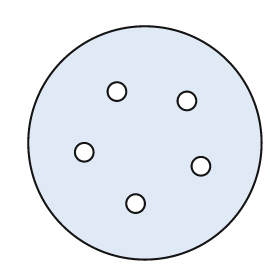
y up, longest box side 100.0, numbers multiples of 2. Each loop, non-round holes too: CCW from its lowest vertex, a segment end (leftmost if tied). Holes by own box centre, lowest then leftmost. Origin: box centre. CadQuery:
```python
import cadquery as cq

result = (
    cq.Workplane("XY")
    .moveTo(0.0, 0.0)
    .circle(50.0)
    .moveTo(-4.0, -26.0)
    .circle(4.0)
    .moveTo(24.0, -10.0)
    .circle(4.0)
    .moveTo(-26.0, -4.0)
    .circle(4.0)
    .moveTo(18.0, 18.0)
    .circle(4.0)
    .moveTo(-12.0, 22.0)
    .circle(4.0)
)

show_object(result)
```